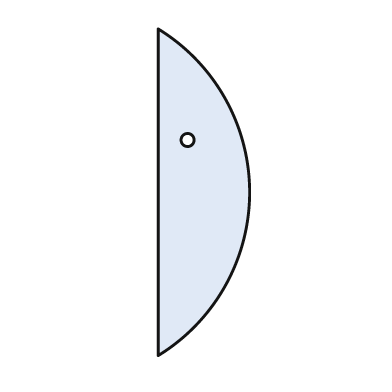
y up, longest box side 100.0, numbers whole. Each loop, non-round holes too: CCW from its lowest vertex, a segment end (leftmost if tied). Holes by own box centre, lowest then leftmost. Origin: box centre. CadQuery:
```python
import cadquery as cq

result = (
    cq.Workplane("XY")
    .moveTo(-14.0, -50.0)
    .threePointArc((14.0, 0.0), (-14.0, 50.0))
    .close()
    .moveTo(-5.0, 16.0)
    .circle(2.0)
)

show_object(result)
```